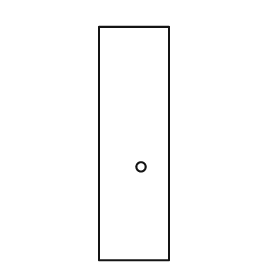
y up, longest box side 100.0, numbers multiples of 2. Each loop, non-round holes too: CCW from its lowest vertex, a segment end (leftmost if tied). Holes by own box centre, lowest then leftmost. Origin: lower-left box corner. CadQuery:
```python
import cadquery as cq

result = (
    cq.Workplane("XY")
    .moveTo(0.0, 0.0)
    .lineTo(30.0, 0.0)
    .lineTo(30.0, 100.0)
    .lineTo(0.0, 100.0)
    .close()
    .moveTo(18.0, 40.0)
    .circle(2.0)
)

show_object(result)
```